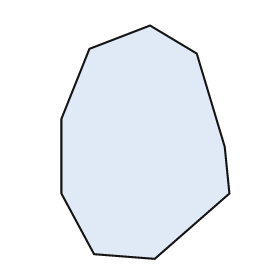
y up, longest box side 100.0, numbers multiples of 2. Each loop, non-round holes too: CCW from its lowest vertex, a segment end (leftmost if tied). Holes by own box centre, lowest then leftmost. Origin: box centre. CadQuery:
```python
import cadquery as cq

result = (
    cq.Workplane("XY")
    .moveTo(4.0, -50.0)
    .lineTo(36.0, -22.0)
    .lineTo(34.0, -2.0)
    .lineTo(22.0, 38.0)
    .lineTo(2.0, 50.0)
    .lineTo(-24.0, 40.0)
    .lineTo(-36.0, 10.0)
    .lineTo(-36.0, -22.0)
    .lineTo(-22.0, -48.0)
    .close()
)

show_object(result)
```